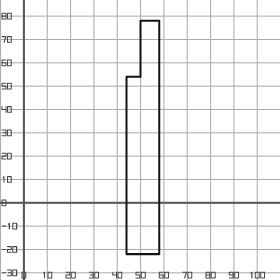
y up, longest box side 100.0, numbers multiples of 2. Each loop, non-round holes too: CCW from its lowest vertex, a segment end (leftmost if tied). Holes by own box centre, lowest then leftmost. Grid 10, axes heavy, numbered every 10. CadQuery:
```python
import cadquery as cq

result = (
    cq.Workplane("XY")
    .moveTo(44.0, -22.0)
    .lineTo(58.0, -22.0)
    .lineTo(58.0, 78.0)
    .lineTo(50.0, 78.0)
    .lineTo(50.0, 54.0)
    .lineTo(44.0, 54.0)
    .close()
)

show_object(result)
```